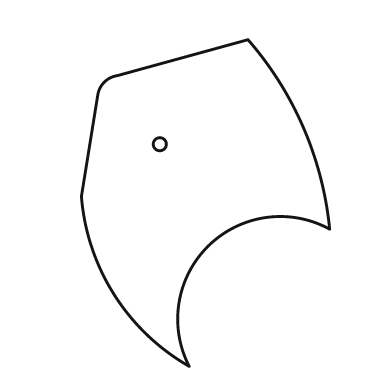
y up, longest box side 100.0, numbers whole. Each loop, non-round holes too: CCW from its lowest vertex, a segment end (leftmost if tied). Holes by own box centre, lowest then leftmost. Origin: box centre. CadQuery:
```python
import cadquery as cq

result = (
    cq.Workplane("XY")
    .moveTo(-5.0, -50.0)
    .threePointArc((1.0, -13.0), (38.0, -8.0))
    .threePointArc((30.0, 23.0), (13.0, 50.0))
    .lineTo(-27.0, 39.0)
    .threePointArc((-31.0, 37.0), (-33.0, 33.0))
    .lineTo(-38.0, 2.0)
    .threePointArc((-28.0, -28.0), (-5.0, -50.0))
    .close()
    .moveTo(-14.0, 18.0)
    .circle(2.0)
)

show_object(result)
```